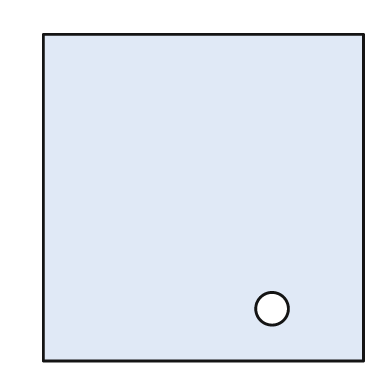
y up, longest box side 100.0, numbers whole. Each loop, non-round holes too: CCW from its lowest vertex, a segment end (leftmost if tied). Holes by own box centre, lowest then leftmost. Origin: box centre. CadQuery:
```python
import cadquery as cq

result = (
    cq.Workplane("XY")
    .moveTo(-49.0, -50.0)
    .lineTo(49.0, -50.0)
    .lineTo(49.0, 50.0)
    .lineTo(-49.0, 50.0)
    .close()
    .moveTo(21.0, -34.0)
    .circle(5.0)
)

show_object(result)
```